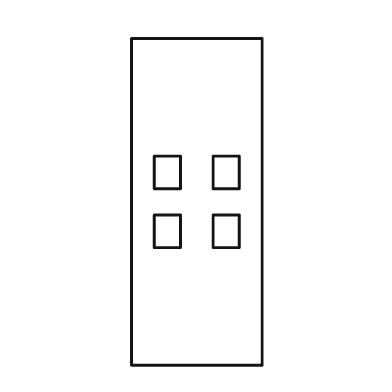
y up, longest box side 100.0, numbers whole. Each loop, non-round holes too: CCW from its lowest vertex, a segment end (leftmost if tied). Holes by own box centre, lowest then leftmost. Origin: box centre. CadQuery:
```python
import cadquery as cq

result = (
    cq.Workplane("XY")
    .moveTo(-20.0, -50.0)
    .lineTo(20.0, -50.0)
    .lineTo(20.0, 50.0)
    .lineTo(-20.0, 50.0)
    .close()
    .moveTo(-13.0, -14.0)
    .lineTo(-5.0, -14.0)
    .lineTo(-5.0, -4.0)
    .lineTo(-13.0, -4.0)
    .close()
    .moveTo(5.0, -14.0)
    .lineTo(13.0, -14.0)
    .lineTo(13.0, -4.0)
    .lineTo(5.0, -4.0)
    .close()
    .moveTo(-13.0, 4.0)
    .lineTo(-5.0, 4.0)
    .lineTo(-5.0, 14.0)
    .lineTo(-13.0, 14.0)
    .close()
    .moveTo(5.0, 4.0)
    .lineTo(13.0, 4.0)
    .lineTo(13.0, 14.0)
    .lineTo(5.0, 14.0)
    .close()
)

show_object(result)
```